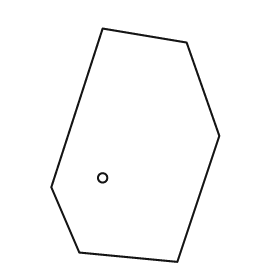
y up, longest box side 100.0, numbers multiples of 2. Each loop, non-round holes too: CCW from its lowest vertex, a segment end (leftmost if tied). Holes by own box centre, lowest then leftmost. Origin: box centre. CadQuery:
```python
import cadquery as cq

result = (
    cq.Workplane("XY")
    .moveTo(18.0, -50.0)
    .lineTo(36.0, 4.0)
    .lineTo(22.0, 44.0)
    .lineTo(-14.0, 50.0)
    .lineTo(-36.0, -18.0)
    .lineTo(-24.0, -46.0)
    .close()
    .moveTo(-14.0, -14.0)
    .circle(2.0)
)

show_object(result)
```